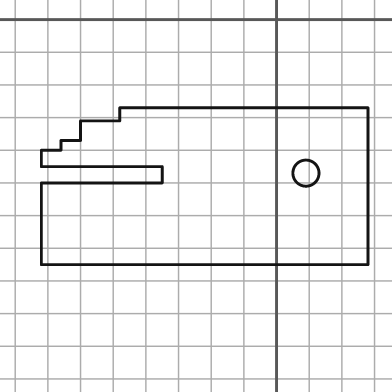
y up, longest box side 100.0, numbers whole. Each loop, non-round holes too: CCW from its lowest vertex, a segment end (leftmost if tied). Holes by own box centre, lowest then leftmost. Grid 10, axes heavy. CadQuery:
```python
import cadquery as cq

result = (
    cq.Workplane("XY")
    .moveTo(-72.0, -75.0)
    .lineTo(28.0, -75.0)
    .lineTo(28.0, -27.0)
    .lineTo(-48.0, -27.0)
    .lineTo(-48.0, -31.0)
    .lineTo(-60.0, -31.0)
    .lineTo(-60.0, -37.0)
    .lineTo(-66.0, -37.0)
    .lineTo(-66.0, -40.0)
    .lineTo(-72.0, -40.0)
    .lineTo(-72.0, -45.0)
    .lineTo(-35.0, -45.0)
    .lineTo(-35.0, -50.0)
    .lineTo(-72.0, -50.0)
    .close()
    .moveTo(9.0, -47.0)
    .circle(4.0)
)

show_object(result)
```